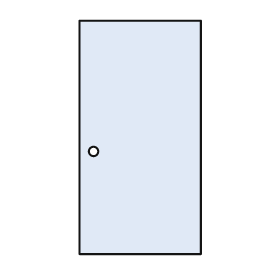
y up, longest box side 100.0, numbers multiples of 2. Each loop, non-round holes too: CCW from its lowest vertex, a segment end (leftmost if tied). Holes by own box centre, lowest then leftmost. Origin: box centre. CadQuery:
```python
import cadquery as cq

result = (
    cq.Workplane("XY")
    .moveTo(-26.0, -50.0)
    .lineTo(26.0, -50.0)
    .lineTo(26.0, 50.0)
    .lineTo(-26.0, 50.0)
    .close()
    .moveTo(-20.0, -6.0)
    .circle(2.0)
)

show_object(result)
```